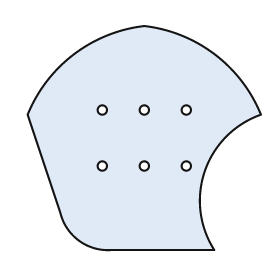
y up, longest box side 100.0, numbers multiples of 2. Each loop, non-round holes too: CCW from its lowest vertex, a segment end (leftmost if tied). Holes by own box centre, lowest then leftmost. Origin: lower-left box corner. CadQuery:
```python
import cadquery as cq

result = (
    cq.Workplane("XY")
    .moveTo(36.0, 0.0)
    .lineTo(80.0, 0.0)
    .threePointArc((76.0, 34.0), (100.0, 58.0))
    .threePointArc((80.0, 84.0), (50.0, 96.0))
    .threePointArc((20.0, 84.0), (0.0, 58.0))
    .lineTo(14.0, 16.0)
    .threePointArc((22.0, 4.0), (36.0, 0.0))
    .close()
    .moveTo(32.0, 36.0)
    .circle(2.0)
    .moveTo(50.0, 36.0)
    .circle(2.0)
    .moveTo(68.0, 36.0)
    .circle(2.0)
    .moveTo(32.0, 60.0)
    .circle(2.0)
    .moveTo(50.0, 60.0)
    .circle(2.0)
    .moveTo(68.0, 60.0)
    .circle(2.0)
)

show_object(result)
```